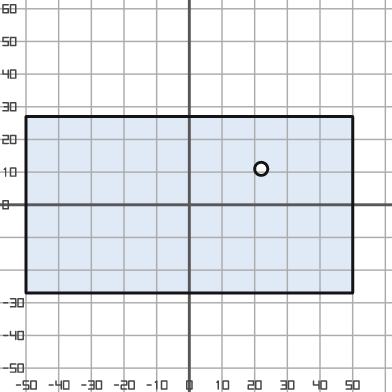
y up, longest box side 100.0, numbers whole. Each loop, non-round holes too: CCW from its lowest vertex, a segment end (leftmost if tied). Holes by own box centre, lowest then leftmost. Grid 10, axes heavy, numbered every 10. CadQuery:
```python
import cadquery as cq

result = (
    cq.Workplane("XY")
    .moveTo(-50.0, -27.0)
    .lineTo(50.0, -27.0)
    .lineTo(50.0, 27.0)
    .lineTo(-50.0, 27.0)
    .close()
    .moveTo(22.0, 11.0)
    .circle(2.0)
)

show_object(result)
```